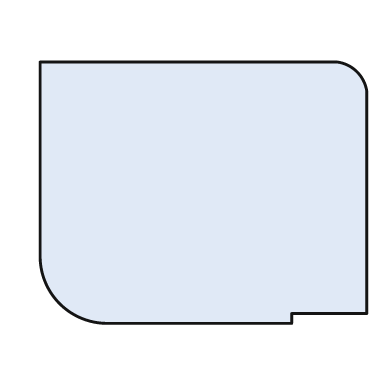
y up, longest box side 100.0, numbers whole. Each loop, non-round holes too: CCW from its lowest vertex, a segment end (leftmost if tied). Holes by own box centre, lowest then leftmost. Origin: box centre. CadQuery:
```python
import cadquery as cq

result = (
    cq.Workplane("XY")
    .moveTo(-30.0, -40.0)
    .lineTo(27.0, -40.0)
    .lineTo(27.0, -37.0)
    .lineTo(50.0, -37.0)
    .lineTo(50.0, 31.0)
    .threePointArc((47.0, 37.0), (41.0, 40.0))
    .lineTo(-50.0, 40.0)
    .lineTo(-50.0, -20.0)
    .threePointArc((-44.0, -34.0), (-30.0, -40.0))
    .close()
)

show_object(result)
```